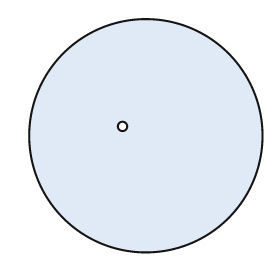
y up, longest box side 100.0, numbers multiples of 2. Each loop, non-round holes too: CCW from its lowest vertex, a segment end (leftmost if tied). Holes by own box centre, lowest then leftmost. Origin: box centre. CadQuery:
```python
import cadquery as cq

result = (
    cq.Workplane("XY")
    .moveTo(0.0, 0.0)
    .circle(50.0)
    .moveTo(-10.0, 4.0)
    .circle(2.0)
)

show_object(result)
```